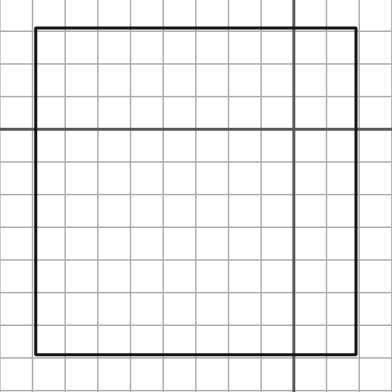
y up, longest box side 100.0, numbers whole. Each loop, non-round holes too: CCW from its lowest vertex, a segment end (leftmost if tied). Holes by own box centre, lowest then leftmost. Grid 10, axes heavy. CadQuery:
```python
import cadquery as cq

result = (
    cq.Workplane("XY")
    .moveTo(-79.0, -69.0)
    .lineTo(19.0, -69.0)
    .lineTo(19.0, 31.0)
    .lineTo(-79.0, 31.0)
    .close()
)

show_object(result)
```